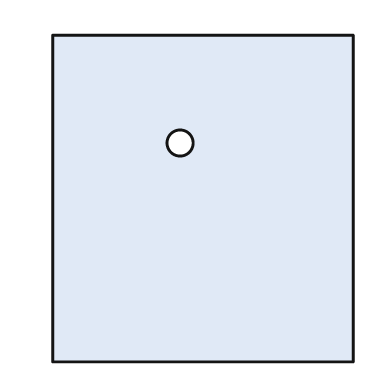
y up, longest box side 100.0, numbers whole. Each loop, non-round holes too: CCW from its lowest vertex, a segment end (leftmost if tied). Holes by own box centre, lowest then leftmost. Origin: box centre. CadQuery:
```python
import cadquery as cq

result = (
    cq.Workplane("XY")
    .moveTo(-46.0, -50.0)
    .lineTo(46.0, -50.0)
    .lineTo(46.0, 50.0)
    .lineTo(-46.0, 50.0)
    .close()
    .moveTo(-7.0, 17.0)
    .circle(4.0)
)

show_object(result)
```